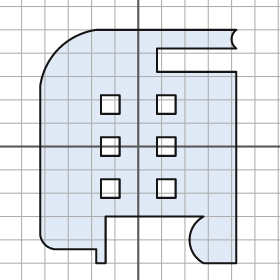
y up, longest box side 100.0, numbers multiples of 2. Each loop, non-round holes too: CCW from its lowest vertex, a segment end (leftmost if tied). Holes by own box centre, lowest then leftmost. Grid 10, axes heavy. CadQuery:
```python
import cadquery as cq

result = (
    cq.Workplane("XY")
    .moveTo(-18.0, -50.0)
    .lineTo(-14.0, -50.0)
    .lineTo(-14.0, -30.0)
    .lineTo(28.0, -30.0)
    .threePointArc((22.0, -40.0), (28.0, -50.0))
    .lineTo(42.0, -50.0)
    .lineTo(42.0, 32.0)
    .lineTo(8.0, 32.0)
    .lineTo(8.0, 42.0)
    .lineTo(42.0, 42.0)
    .threePointArc((40.0, 46.0), (42.0, 50.0))
    .lineTo(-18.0, 50.0)
    .threePointArc((-34.0, 42.0), (-42.0, 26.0))
    .lineTo(-42.0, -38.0)
    .threePointArc((-40.0, -42.0), (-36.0, -44.0))
    .lineTo(-18.0, -44.0)
    .close()
    .moveTo(-16.0, -22.0)
    .lineTo(-8.0, -22.0)
    .lineTo(-8.0, -14.0)
    .lineTo(-16.0, -14.0)
    .close()
    .moveTo(8.0, -22.0)
    .lineTo(16.0, -22.0)
    .lineTo(16.0, -14.0)
    .lineTo(8.0, -14.0)
    .close()
    .moveTo(-16.0, -4.0)
    .lineTo(-8.0, -4.0)
    .lineTo(-8.0, 4.0)
    .lineTo(-16.0, 4.0)
    .close()
    .moveTo(8.0, -4.0)
    .lineTo(16.0, -4.0)
    .lineTo(16.0, 4.0)
    .lineTo(8.0, 4.0)
    .close()
    .moveTo(-16.0, 14.0)
    .lineTo(-8.0, 14.0)
    .lineTo(-8.0, 22.0)
    .lineTo(-16.0, 22.0)
    .close()
    .moveTo(8.0, 14.0)
    .lineTo(16.0, 14.0)
    .lineTo(16.0, 22.0)
    .lineTo(8.0, 22.0)
    .close()
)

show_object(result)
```